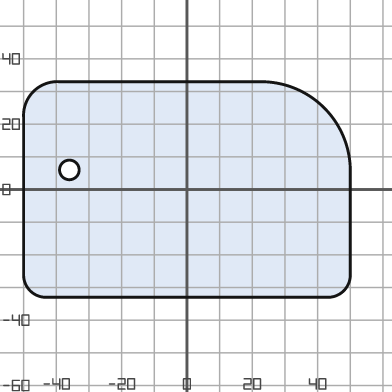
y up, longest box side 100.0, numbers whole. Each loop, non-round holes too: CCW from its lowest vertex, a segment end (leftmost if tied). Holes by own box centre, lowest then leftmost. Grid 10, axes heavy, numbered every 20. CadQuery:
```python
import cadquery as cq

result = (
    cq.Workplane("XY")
    .moveTo(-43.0, -33.0)
    .lineTo(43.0, -33.0)
    .threePointArc((48.0, -31.0), (50.0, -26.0))
    .lineTo(50.0, 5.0)
    .threePointArc((42.0, 25.0), (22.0, 33.0))
    .lineTo(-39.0, 33.0)
    .threePointArc((-47.0, 30.0), (-50.0, 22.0))
    .lineTo(-50.0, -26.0)
    .threePointArc((-48.0, -31.0), (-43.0, -33.0))
    .close()
    .moveTo(-36.0, 6.0)
    .circle(3.0)
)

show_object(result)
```